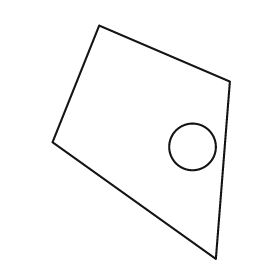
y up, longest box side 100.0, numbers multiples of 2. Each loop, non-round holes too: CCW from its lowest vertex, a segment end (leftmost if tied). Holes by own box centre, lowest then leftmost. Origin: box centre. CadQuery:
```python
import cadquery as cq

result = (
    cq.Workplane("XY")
    .moveTo(32.0, -50.0)
    .lineTo(38.0, 26.0)
    .lineTo(-18.0, 50.0)
    .lineTo(-38.0, 0.0)
    .close()
    .moveTo(22.0, -2.0)
    .circle(10.0)
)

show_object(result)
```